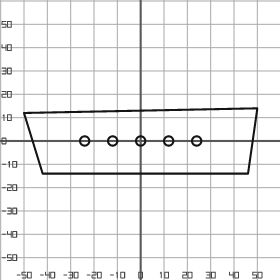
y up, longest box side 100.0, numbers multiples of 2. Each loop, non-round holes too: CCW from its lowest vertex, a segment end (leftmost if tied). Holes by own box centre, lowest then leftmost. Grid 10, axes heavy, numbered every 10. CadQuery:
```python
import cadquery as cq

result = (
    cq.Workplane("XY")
    .moveTo(-42.0, -14.0)
    .lineTo(46.0, -14.0)
    .lineTo(50.0, 14.0)
    .lineTo(-50.0, 12.0)
    .close()
    .moveTo(-24.0, 0.0)
    .circle(2.0)
    .moveTo(-12.0, 0.0)
    .circle(2.0)
    .moveTo(0.0, 0.0)
    .circle(2.0)
    .moveTo(12.0, 0.0)
    .circle(2.0)
    .moveTo(24.0, 0.0)
    .circle(2.0)
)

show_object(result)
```